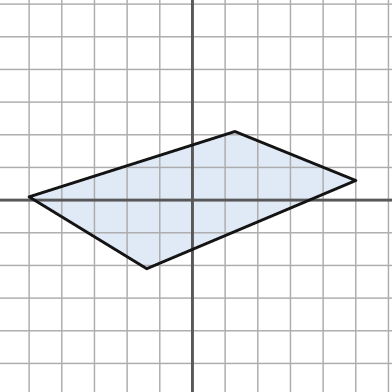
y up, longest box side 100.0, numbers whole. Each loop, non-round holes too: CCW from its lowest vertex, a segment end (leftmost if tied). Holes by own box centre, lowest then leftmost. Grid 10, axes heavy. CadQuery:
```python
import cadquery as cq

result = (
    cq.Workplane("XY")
    .moveTo(-14.0, -21.0)
    .lineTo(50.0, 6.0)
    .lineTo(13.0, 21.0)
    .lineTo(-50.0, 1.0)
    .close()
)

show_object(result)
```